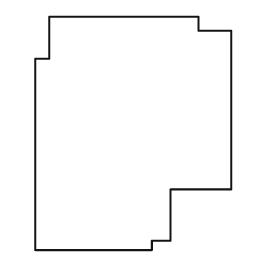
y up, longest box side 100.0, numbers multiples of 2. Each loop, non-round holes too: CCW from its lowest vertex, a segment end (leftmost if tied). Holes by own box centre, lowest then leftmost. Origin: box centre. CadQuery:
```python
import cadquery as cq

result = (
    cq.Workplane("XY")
    .moveTo(-42.0, -50.0)
    .lineTo(8.0, -50.0)
    .lineTo(8.0, -46.0)
    .lineTo(16.0, -46.0)
    .lineTo(16.0, -24.0)
    .lineTo(42.0, -24.0)
    .lineTo(42.0, 44.0)
    .lineTo(28.0, 44.0)
    .lineTo(28.0, 50.0)
    .lineTo(-36.0, 50.0)
    .lineTo(-36.0, 32.0)
    .lineTo(-42.0, 32.0)
    .close()
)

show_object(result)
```